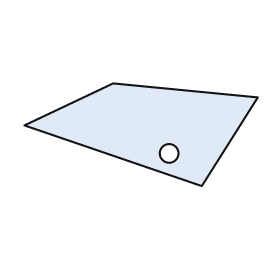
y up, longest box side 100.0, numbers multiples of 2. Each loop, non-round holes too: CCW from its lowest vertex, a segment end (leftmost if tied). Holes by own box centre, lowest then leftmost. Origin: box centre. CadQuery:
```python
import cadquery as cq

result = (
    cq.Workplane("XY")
    .moveTo(26.0, -22.0)
    .lineTo(50.0, 16.0)
    .lineTo(-12.0, 22.0)
    .lineTo(-50.0, 4.0)
    .close()
    .moveTo(12.0, -8.0)
    .circle(4.0)
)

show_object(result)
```